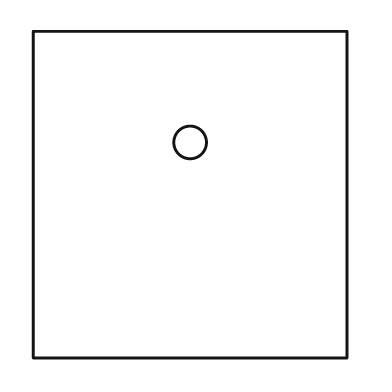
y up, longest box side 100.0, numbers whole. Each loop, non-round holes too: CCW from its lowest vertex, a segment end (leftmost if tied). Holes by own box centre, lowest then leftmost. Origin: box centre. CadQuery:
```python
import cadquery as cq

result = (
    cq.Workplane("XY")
    .moveTo(-48.0, -50.0)
    .lineTo(48.0, -50.0)
    .lineTo(48.0, 50.0)
    .lineTo(-48.0, 50.0)
    .close()
    .moveTo(0.0, 16.0)
    .circle(5.0)
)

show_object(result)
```